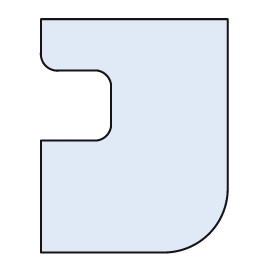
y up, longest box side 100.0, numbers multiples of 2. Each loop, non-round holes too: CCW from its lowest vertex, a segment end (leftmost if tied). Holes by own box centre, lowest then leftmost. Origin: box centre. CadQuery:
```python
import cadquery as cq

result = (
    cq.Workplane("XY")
    .moveTo(-40.0, -50.0)
    .lineTo(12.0, -50.0)
    .threePointArc((32.0, -42.0), (40.0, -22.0))
    .lineTo(40.0, 50.0)
    .lineTo(-40.0, 50.0)
    .lineTo(-40.0, 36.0)
    .threePointArc((-38.0, 30.0), (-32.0, 28.0))
    .lineTo(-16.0, 28.0)
    .threePointArc((-12.0, 26.0), (-10.0, 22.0))
    .lineTo(-10.0, 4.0)
    .threePointArc((-12.0, 0.0), (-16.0, -2.0))
    .lineTo(-40.0, -2.0)
    .close()
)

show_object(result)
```